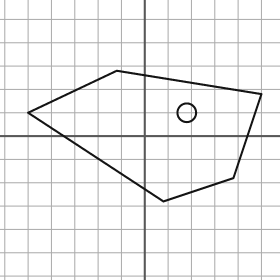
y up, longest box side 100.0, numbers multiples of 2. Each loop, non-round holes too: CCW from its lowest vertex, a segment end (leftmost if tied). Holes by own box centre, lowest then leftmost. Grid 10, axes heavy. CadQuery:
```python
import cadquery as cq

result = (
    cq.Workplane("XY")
    .moveTo(8.0, -28.0)
    .lineTo(38.0, -18.0)
    .lineTo(50.0, 18.0)
    .lineTo(-12.0, 28.0)
    .lineTo(-50.0, 10.0)
    .close()
    .moveTo(18.0, 10.0)
    .circle(4.0)
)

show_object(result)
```